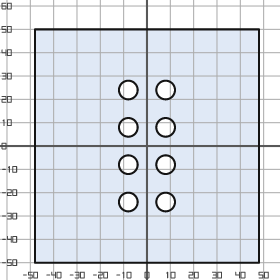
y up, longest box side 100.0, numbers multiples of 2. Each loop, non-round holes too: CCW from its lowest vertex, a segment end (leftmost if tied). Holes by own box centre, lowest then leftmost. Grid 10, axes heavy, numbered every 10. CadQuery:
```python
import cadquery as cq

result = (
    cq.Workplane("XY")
    .moveTo(-48.0, -50.0)
    .lineTo(48.0, -50.0)
    .lineTo(48.0, 50.0)
    .lineTo(-48.0, 50.0)
    .close()
    .moveTo(-8.0, -24.0)
    .circle(4.0)
    .moveTo(8.0, -24.0)
    .circle(4.0)
    .moveTo(-8.0, -8.0)
    .circle(4.0)
    .moveTo(8.0, -8.0)
    .circle(4.0)
    .moveTo(-8.0, 8.0)
    .circle(4.0)
    .moveTo(8.0, 8.0)
    .circle(4.0)
    .moveTo(-8.0, 24.0)
    .circle(4.0)
    .moveTo(8.0, 24.0)
    .circle(4.0)
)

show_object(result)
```